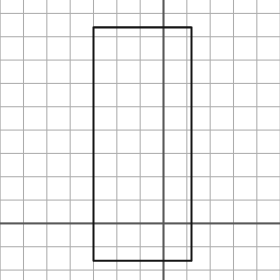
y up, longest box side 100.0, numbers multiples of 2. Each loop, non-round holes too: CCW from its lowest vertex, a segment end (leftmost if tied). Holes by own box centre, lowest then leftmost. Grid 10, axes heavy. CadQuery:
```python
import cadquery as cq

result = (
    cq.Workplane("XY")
    .moveTo(-30.0, -16.0)
    .lineTo(12.0, -16.0)
    .lineTo(12.0, 84.0)
    .lineTo(-30.0, 84.0)
    .close()
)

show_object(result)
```